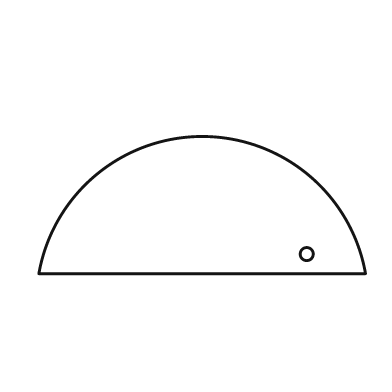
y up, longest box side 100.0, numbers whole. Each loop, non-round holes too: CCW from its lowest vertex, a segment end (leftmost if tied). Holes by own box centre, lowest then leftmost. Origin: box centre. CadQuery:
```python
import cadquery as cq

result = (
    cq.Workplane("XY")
    .moveTo(-50.0, -21.0)
    .lineTo(50.0, -21.0)
    .threePointArc((0.0, 21.0), (-50.0, -21.0))
    .close()
    .moveTo(32.0, -15.0)
    .circle(2.0)
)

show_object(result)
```